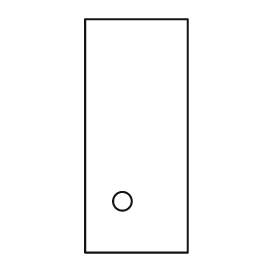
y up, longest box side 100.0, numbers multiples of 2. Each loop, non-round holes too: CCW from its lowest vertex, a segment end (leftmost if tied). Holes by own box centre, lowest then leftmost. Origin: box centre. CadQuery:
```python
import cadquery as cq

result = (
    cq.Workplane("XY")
    .moveTo(-22.0, -50.0)
    .lineTo(22.0, -50.0)
    .lineTo(22.0, 50.0)
    .lineTo(-22.0, 50.0)
    .close()
    .moveTo(-6.0, -28.0)
    .circle(4.0)
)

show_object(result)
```